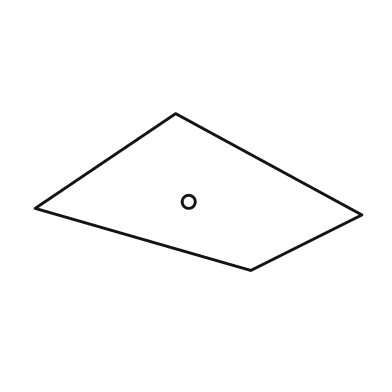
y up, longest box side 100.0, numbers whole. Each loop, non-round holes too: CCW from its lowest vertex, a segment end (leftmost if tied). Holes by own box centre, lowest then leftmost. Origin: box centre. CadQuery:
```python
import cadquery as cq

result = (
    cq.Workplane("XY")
    .moveTo(16.0, -24.0)
    .lineTo(50.0, -7.0)
    .lineTo(-7.0, 24.0)
    .lineTo(-50.0, -5.0)
    .close()
    .moveTo(-3.0, -3.0)
    .circle(2.0)
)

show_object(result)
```